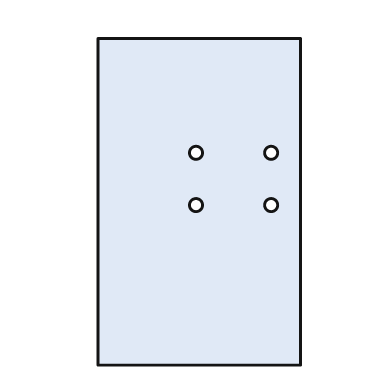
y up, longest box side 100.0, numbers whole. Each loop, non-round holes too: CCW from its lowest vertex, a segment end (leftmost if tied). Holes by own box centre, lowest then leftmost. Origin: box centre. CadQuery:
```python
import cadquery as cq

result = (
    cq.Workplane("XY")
    .moveTo(-31.0, -50.0)
    .lineTo(31.0, -50.0)
    .lineTo(31.0, 50.0)
    .lineTo(-31.0, 50.0)
    .close()
    .moveTo(-1.0, -1.0)
    .circle(2.0)
    .moveTo(22.0, -1.0)
    .circle(2.0)
    .moveTo(-1.0, 15.0)
    .circle(2.0)
    .moveTo(22.0, 15.0)
    .circle(2.0)
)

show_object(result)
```